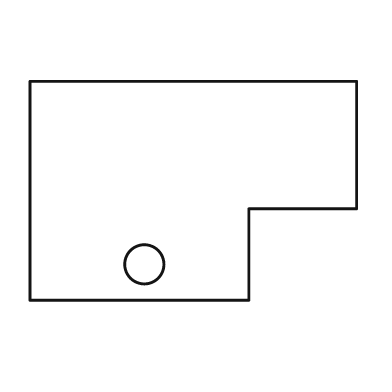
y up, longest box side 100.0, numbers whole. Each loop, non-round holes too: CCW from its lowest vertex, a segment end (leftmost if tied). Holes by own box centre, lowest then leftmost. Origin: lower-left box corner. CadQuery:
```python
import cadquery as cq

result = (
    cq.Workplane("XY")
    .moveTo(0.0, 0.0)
    .lineTo(67.0, 0.0)
    .lineTo(67.0, 28.0)
    .lineTo(100.0, 28.0)
    .lineTo(100.0, 67.0)
    .lineTo(0.0, 67.0)
    .close()
    .moveTo(35.0, 11.0)
    .circle(6.0)
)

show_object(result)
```